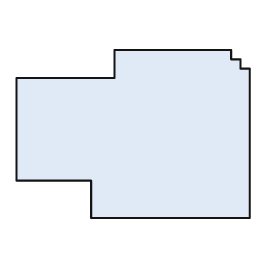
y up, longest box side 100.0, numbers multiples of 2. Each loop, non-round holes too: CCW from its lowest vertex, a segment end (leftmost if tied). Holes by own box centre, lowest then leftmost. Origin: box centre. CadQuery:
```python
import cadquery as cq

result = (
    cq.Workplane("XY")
    .moveTo(-18.0, -36.0)
    .lineTo(50.0, -36.0)
    .lineTo(50.0, 28.0)
    .lineTo(46.0, 28.0)
    .lineTo(46.0, 32.0)
    .lineTo(42.0, 32.0)
    .lineTo(42.0, 36.0)
    .lineTo(-8.0, 36.0)
    .lineTo(-8.0, 24.0)
    .lineTo(-50.0, 24.0)
    .lineTo(-50.0, -20.0)
    .lineTo(-18.0, -20.0)
    .close()
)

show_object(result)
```